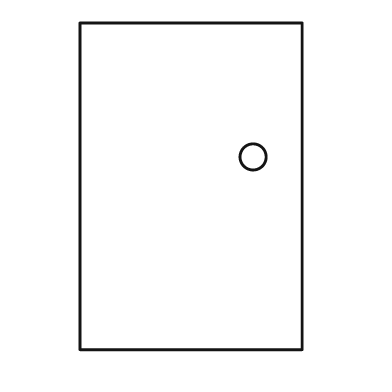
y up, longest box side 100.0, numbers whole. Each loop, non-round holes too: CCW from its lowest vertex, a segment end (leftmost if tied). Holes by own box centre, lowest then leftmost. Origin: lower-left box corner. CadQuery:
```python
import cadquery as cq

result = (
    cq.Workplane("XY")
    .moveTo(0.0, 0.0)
    .lineTo(68.0, 0.0)
    .lineTo(68.0, 100.0)
    .lineTo(0.0, 100.0)
    .close()
    .moveTo(53.0, 59.0)
    .circle(4.0)
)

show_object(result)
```